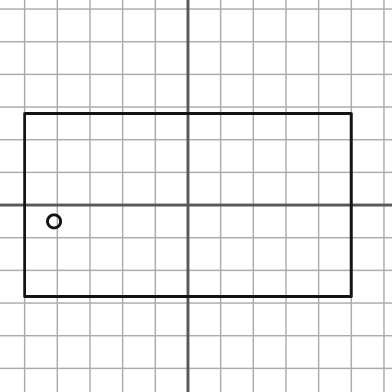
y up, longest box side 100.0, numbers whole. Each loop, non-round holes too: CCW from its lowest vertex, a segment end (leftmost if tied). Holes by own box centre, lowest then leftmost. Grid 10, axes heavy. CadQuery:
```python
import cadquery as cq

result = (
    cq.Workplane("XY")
    .moveTo(-50.0, -28.0)
    .lineTo(50.0, -28.0)
    .lineTo(50.0, 28.0)
    .lineTo(-50.0, 28.0)
    .close()
    .moveTo(-41.0, -5.0)
    .circle(2.0)
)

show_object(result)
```